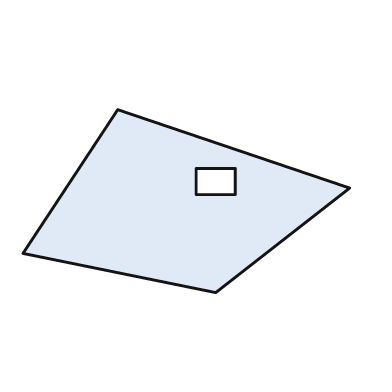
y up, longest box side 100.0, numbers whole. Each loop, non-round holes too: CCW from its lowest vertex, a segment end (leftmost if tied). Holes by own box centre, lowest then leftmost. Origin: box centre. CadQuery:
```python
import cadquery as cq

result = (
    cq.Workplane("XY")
    .moveTo(9.0, -28.0)
    .lineTo(50.0, 4.0)
    .lineTo(-21.0, 28.0)
    .lineTo(-50.0, -16.0)
    .close()
    .moveTo(3.0, 2.0)
    .lineTo(15.0, 2.0)
    .lineTo(15.0, 10.0)
    .lineTo(3.0, 10.0)
    .close()
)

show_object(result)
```